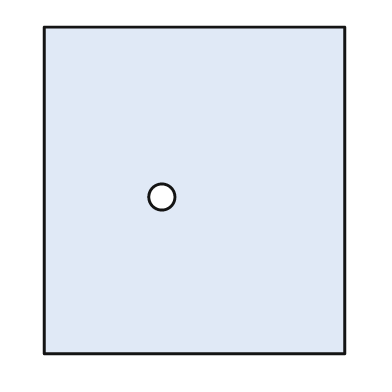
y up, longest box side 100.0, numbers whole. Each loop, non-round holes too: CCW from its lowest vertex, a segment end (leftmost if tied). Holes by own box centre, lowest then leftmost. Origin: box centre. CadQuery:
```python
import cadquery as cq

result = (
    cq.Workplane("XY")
    .moveTo(-46.0, -50.0)
    .lineTo(46.0, -50.0)
    .lineTo(46.0, 50.0)
    .lineTo(-46.0, 50.0)
    .close()
    .moveTo(-10.0, -2.0)
    .circle(4.0)
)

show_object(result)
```